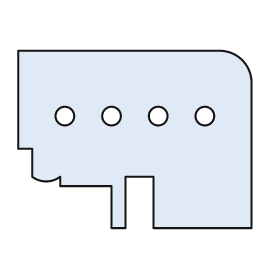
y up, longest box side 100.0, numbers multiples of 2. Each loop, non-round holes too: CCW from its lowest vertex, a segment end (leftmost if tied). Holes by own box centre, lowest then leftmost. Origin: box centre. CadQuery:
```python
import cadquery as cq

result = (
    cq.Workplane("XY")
    .moveTo(-10.0, -38.0)
    .lineTo(-4.0, -38.0)
    .lineTo(-4.0, -16.0)
    .lineTo(8.0, -16.0)
    .lineTo(8.0, -38.0)
    .lineTo(50.0, -38.0)
    .lineTo(50.0, 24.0)
    .threePointArc((46.0, 34.0), (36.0, 38.0))
    .lineTo(-50.0, 38.0)
    .lineTo(-50.0, -4.0)
    .lineTo(-44.0, -4.0)
    .lineTo(-44.0, -16.0)
    .threePointArc((-38.0, -18.0), (-32.0, -16.0))
    .lineTo(-32.0, -20.0)
    .lineTo(-10.0, -20.0)
    .close()
    .moveTo(-30.0, 10.0)
    .circle(4.0)
    .moveTo(-10.0, 10.0)
    .circle(4.0)
    .moveTo(10.0, 10.0)
    .circle(4.0)
    .moveTo(30.0, 10.0)
    .circle(4.0)
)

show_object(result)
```